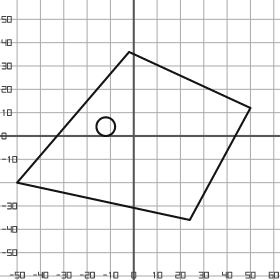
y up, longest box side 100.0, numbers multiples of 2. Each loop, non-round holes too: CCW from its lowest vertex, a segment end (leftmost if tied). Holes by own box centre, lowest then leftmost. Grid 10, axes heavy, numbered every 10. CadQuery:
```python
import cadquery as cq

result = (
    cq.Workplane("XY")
    .moveTo(24.0, -36.0)
    .lineTo(50.0, 12.0)
    .lineTo(-2.0, 36.0)
    .lineTo(-50.0, -20.0)
    .close()
    .moveTo(-12.0, 4.0)
    .circle(4.0)
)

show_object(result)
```